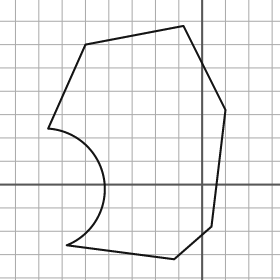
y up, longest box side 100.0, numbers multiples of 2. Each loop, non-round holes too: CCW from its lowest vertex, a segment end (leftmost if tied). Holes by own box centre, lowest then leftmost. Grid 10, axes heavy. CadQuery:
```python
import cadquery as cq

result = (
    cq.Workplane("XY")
    .moveTo(-12.0, -32.0)
    .lineTo(4.0, -18.0)
    .lineTo(10.0, 32.0)
    .lineTo(-8.0, 68.0)
    .lineTo(-50.0, 60.0)
    .lineTo(-66.0, 24.0)
    .threePointArc((-42.0, 2.0), (-58.0, -26.0))
    .close()
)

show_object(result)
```